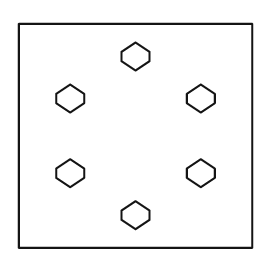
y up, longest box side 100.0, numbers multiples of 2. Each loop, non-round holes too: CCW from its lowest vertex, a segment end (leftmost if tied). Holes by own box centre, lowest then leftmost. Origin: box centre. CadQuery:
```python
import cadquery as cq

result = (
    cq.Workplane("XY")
    .moveTo(-50.0, -48.0)
    .lineTo(50.0, -48.0)
    .lineTo(50.0, 48.0)
    .lineTo(-50.0, 48.0)
    .close()
    .moveTo(0.0, -40.0)
    .lineTo(6.0, -36.0)
    .lineTo(6.0, -32.0)
    .lineTo(0.0, -28.0)
    .lineTo(-6.0, -32.0)
    .lineTo(-6.0, -36.0)
    .close()
    .moveTo(-28.0, -22.0)
    .lineTo(-22.0, -18.0)
    .lineTo(-22.0, -14.0)
    .lineTo(-28.0, -10.0)
    .lineTo(-34.0, -14.0)
    .lineTo(-34.0, -18.0)
    .close()
    .moveTo(28.0, -22.0)
    .lineTo(34.0, -18.0)
    .lineTo(34.0, -14.0)
    .lineTo(28.0, -10.0)
    .lineTo(22.0, -14.0)
    .lineTo(22.0, -18.0)
    .close()
    .moveTo(-28.0, 10.0)
    .lineTo(-22.0, 14.0)
    .lineTo(-22.0, 18.0)
    .lineTo(-28.0, 22.0)
    .lineTo(-34.0, 18.0)
    .lineTo(-34.0, 14.0)
    .close()
    .moveTo(28.0, 10.0)
    .lineTo(34.0, 14.0)
    .lineTo(34.0, 18.0)
    .lineTo(28.0, 22.0)
    .lineTo(22.0, 18.0)
    .lineTo(22.0, 14.0)
    .close()
    .moveTo(0.0, 28.0)
    .lineTo(6.0, 32.0)
    .lineTo(6.0, 36.0)
    .lineTo(0.0, 40.0)
    .lineTo(-6.0, 36.0)
    .lineTo(-6.0, 32.0)
    .close()
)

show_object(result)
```